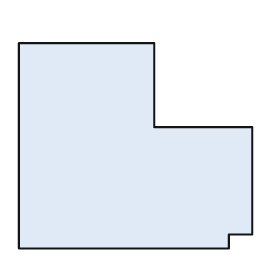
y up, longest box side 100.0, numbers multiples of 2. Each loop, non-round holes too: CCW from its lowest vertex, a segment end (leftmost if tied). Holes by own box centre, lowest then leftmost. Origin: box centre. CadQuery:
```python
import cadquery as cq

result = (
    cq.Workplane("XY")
    .moveTo(-50.0, -44.0)
    .lineTo(40.0, -44.0)
    .lineTo(40.0, -38.0)
    .lineTo(50.0, -38.0)
    .lineTo(50.0, 8.0)
    .lineTo(8.0, 8.0)
    .lineTo(8.0, 44.0)
    .lineTo(-50.0, 44.0)
    .close()
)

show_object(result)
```